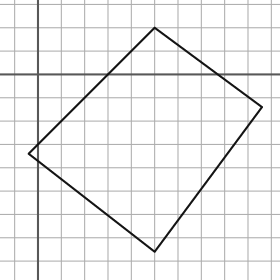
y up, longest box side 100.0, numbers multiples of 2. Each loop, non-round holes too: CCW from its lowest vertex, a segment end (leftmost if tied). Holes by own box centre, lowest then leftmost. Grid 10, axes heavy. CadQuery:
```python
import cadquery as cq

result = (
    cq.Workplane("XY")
    .moveTo(50.0, -76.0)
    .lineTo(96.0, -14.0)
    .lineTo(50.0, 20.0)
    .lineTo(-4.0, -34.0)
    .close()
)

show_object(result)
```